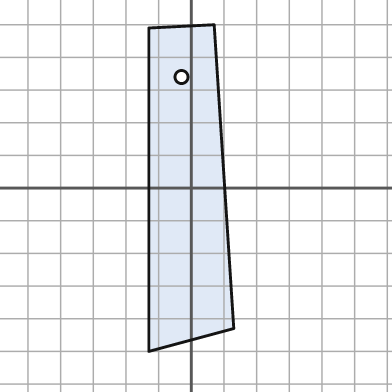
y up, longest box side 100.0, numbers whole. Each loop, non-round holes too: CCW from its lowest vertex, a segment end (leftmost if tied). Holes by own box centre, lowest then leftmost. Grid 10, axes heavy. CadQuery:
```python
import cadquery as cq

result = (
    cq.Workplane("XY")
    .moveTo(-13.0, -50.0)
    .lineTo(13.0, -43.0)
    .lineTo(7.0, 50.0)
    .lineTo(-13.0, 49.0)
    .close()
    .moveTo(-3.0, 34.0)
    .circle(2.0)
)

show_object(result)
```